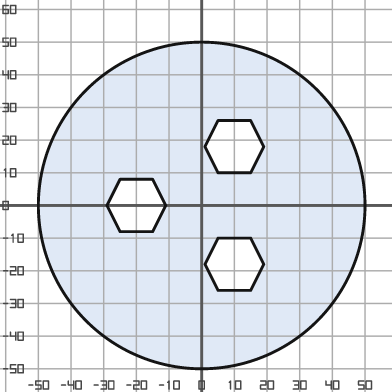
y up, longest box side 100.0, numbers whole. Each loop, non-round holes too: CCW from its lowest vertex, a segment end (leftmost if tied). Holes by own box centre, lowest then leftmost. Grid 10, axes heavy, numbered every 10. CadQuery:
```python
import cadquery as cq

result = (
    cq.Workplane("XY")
    .moveTo(0.0, 0.0)
    .circle(50.0)
    .moveTo(5.0, -26.0)
    .lineTo(15.0, -26.0)
    .lineTo(19.0, -18.0)
    .lineTo(15.0, -10.0)
    .lineTo(5.0, -10.0)
    .lineTo(1.0, -18.0)
    .close()
    .moveTo(-25.0, -8.0)
    .lineTo(-15.0, -8.0)
    .lineTo(-11.0, 0.0)
    .lineTo(-15.0, 8.0)
    .lineTo(-25.0, 8.0)
    .lineTo(-29.0, 0.0)
    .close()
    .moveTo(5.0, 10.0)
    .lineTo(15.0, 10.0)
    .lineTo(19.0, 18.0)
    .lineTo(15.0, 26.0)
    .lineTo(5.0, 26.0)
    .lineTo(1.0, 18.0)
    .close()
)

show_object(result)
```